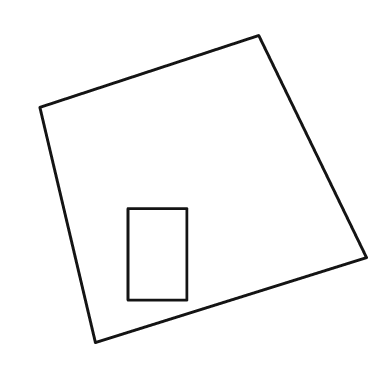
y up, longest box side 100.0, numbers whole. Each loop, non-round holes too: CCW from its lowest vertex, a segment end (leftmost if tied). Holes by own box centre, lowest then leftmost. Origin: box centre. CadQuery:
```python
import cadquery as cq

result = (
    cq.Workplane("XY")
    .moveTo(-33.0, -47.0)
    .lineTo(50.0, -21.0)
    .lineTo(17.0, 47.0)
    .lineTo(-50.0, 25.0)
    .close()
    .moveTo(-23.0, -34.0)
    .lineTo(-5.0, -34.0)
    .lineTo(-5.0, -6.0)
    .lineTo(-23.0, -6.0)
    .close()
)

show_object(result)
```